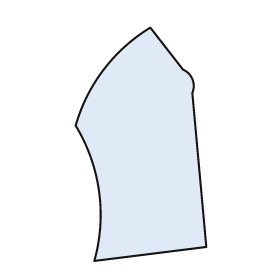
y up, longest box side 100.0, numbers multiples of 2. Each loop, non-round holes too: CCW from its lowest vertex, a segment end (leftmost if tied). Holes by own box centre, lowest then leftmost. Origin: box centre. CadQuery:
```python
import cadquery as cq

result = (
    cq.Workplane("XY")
    .moveTo(-20.0, -50.0)
    .lineTo(28.0, -44.0)
    .lineTo(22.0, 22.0)
    .threePointArc((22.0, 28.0), (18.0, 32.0))
    .lineTo(4.0, 50.0)
    .threePointArc((-16.0, 32.0), (-28.0, 8.0))
    .threePointArc((-18.0, -20.0), (-20.0, -50.0))
    .close()
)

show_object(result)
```